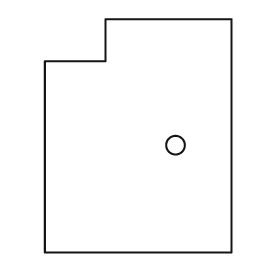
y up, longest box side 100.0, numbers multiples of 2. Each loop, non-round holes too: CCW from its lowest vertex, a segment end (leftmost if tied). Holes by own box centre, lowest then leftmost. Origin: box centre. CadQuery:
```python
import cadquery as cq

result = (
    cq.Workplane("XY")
    .moveTo(-40.0, -50.0)
    .lineTo(40.0, -50.0)
    .lineTo(40.0, 50.0)
    .lineTo(-14.0, 50.0)
    .lineTo(-14.0, 32.0)
    .lineTo(-40.0, 32.0)
    .close()
    .moveTo(16.0, -4.0)
    .circle(4.0)
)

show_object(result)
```